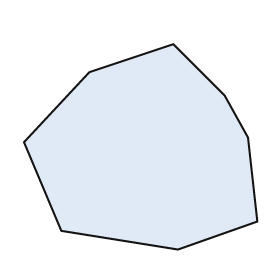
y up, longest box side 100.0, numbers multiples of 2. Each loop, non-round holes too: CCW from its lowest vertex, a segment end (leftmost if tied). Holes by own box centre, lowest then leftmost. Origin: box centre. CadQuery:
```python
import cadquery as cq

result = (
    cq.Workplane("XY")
    .moveTo(16.0, -44.0)
    .lineTo(50.0, -32.0)
    .lineTo(46.0, 4.0)
    .lineTo(36.0, 22.0)
    .lineTo(14.0, 44.0)
    .lineTo(-22.0, 32.0)
    .lineTo(-50.0, 2.0)
    .lineTo(-34.0, -36.0)
    .close()
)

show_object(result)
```